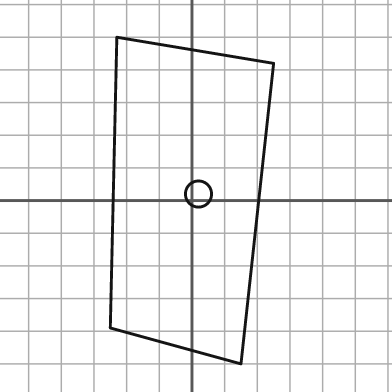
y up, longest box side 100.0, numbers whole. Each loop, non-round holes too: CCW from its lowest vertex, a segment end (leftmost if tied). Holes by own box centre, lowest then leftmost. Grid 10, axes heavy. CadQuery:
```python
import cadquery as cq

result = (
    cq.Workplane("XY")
    .moveTo(15.0, -50.0)
    .lineTo(25.0, 42.0)
    .lineTo(-23.0, 50.0)
    .lineTo(-25.0, -39.0)
    .close()
    .moveTo(2.0, 2.0)
    .circle(4.0)
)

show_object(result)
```